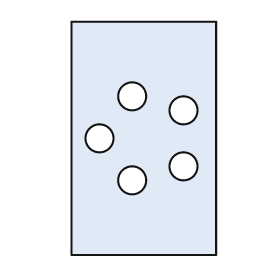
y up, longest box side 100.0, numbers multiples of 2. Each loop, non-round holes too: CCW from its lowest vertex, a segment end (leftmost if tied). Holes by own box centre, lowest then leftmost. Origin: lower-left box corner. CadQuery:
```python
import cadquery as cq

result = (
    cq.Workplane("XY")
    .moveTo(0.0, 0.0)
    .lineTo(62.0, 0.0)
    .lineTo(62.0, 100.0)
    .lineTo(0.0, 100.0)
    .close()
    .moveTo(26.0, 32.0)
    .circle(6.0)
    .moveTo(48.0, 38.0)
    .circle(6.0)
    .moveTo(12.0, 50.0)
    .circle(6.0)
    .moveTo(48.0, 62.0)
    .circle(6.0)
    .moveTo(26.0, 68.0)
    .circle(6.0)
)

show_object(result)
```